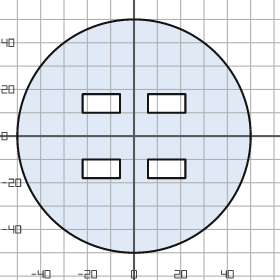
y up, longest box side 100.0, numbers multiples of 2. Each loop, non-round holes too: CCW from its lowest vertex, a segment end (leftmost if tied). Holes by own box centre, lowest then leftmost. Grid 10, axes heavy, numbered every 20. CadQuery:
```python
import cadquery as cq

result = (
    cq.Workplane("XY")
    .moveTo(0.0, 0.0)
    .circle(50.0)
    .moveTo(-22.0, -18.0)
    .lineTo(-6.0, -18.0)
    .lineTo(-6.0, -10.0)
    .lineTo(-22.0, -10.0)
    .close()
    .moveTo(6.0, -18.0)
    .lineTo(22.0, -18.0)
    .lineTo(22.0, -10.0)
    .lineTo(6.0, -10.0)
    .close()
    .moveTo(-22.0, 10.0)
    .lineTo(-6.0, 10.0)
    .lineTo(-6.0, 18.0)
    .lineTo(-22.0, 18.0)
    .close()
    .moveTo(6.0, 10.0)
    .lineTo(22.0, 10.0)
    .lineTo(22.0, 18.0)
    .lineTo(6.0, 18.0)
    .close()
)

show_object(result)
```